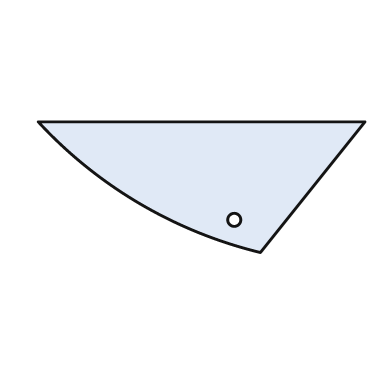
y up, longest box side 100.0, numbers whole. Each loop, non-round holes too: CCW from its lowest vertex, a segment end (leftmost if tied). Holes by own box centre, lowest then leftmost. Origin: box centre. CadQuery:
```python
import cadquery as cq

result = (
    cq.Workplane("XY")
    .moveTo(18.0, -20.0)
    .lineTo(50.0, 20.0)
    .lineTo(-50.0, 20.0)
    .threePointArc((-19.0, -5.0), (18.0, -20.0))
    .close()
    .moveTo(10.0, -10.0)
    .circle(2.0)
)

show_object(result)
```